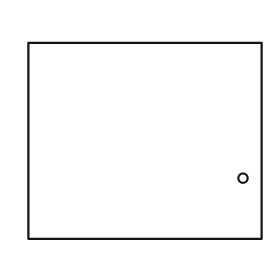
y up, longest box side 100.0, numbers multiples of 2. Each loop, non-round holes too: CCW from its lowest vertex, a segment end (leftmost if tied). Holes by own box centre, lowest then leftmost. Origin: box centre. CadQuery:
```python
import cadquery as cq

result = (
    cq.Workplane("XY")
    .moveTo(-50.0, -42.0)
    .lineTo(50.0, -42.0)
    .lineTo(50.0, 42.0)
    .lineTo(-50.0, 42.0)
    .close()
    .moveTo(42.0, -16.0)
    .circle(2.0)
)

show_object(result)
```